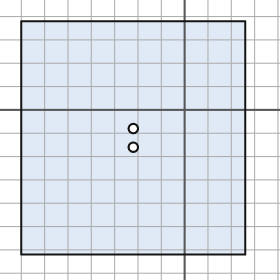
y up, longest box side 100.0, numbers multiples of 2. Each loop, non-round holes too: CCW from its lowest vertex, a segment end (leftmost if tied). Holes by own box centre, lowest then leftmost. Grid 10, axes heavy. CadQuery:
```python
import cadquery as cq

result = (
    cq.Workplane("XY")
    .moveTo(-70.0, -62.0)
    .lineTo(26.0, -62.0)
    .lineTo(26.0, 38.0)
    .lineTo(-70.0, 38.0)
    .close()
    .moveTo(-22.0, -16.0)
    .circle(2.0)
    .moveTo(-22.0, -8.0)
    .circle(2.0)
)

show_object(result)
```